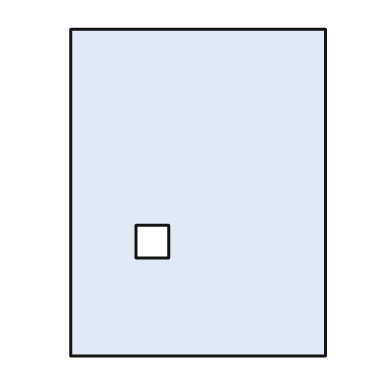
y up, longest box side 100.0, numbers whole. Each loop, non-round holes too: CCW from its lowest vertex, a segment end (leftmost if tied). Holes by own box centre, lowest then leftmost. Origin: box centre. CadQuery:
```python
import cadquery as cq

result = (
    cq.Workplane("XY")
    .moveTo(-39.0, -50.0)
    .lineTo(39.0, -50.0)
    .lineTo(39.0, 50.0)
    .lineTo(-39.0, 50.0)
    .close()
    .moveTo(-19.0, -20.0)
    .lineTo(-9.0, -20.0)
    .lineTo(-9.0, -10.0)
    .lineTo(-19.0, -10.0)
    .close()
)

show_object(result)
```